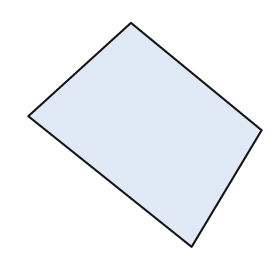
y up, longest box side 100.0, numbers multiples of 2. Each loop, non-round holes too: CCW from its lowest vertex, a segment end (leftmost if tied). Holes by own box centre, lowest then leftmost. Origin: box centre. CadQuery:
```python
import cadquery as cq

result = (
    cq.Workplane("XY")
    .moveTo(20.0, -48.0)
    .lineTo(50.0, 2.0)
    .lineTo(-6.0, 48.0)
    .lineTo(-50.0, 8.0)
    .close()
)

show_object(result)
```